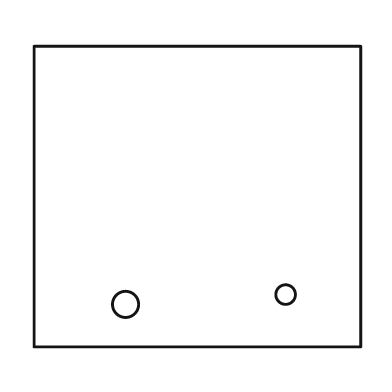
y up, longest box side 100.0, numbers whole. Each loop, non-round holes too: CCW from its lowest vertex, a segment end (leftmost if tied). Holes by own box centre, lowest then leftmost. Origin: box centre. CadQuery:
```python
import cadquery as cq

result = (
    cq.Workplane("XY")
    .moveTo(-50.0, -46.0)
    .lineTo(50.0, -46.0)
    .lineTo(50.0, 46.0)
    .lineTo(-50.0, 46.0)
    .close()
    .moveTo(-22.0, -33.0)
    .circle(4.0)
    .moveTo(27.0, -30.0)
    .circle(3.0)
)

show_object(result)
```